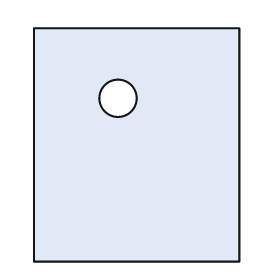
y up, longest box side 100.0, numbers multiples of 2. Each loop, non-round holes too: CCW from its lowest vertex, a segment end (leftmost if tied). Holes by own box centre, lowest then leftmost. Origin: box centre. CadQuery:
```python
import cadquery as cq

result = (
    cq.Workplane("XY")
    .moveTo(-44.0, -50.0)
    .lineTo(44.0, -50.0)
    .lineTo(44.0, 50.0)
    .lineTo(-44.0, 50.0)
    .close()
    .moveTo(-8.0, 20.0)
    .circle(8.0)
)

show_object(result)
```